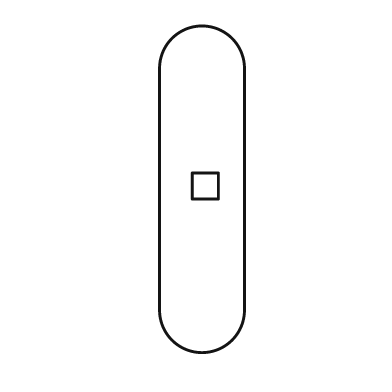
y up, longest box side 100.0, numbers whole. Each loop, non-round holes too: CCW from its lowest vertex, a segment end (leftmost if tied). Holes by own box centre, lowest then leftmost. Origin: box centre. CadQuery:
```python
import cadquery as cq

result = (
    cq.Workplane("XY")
    .moveTo(-13.0, -37.0)
    .threePointArc((0.0, -50.0), (13.0, -37.0))
    .lineTo(13.0, 37.0)
    .threePointArc((0.0, 50.0), (-13.0, 37.0))
    .close()
    .moveTo(-3.0, -3.0)
    .lineTo(5.0, -3.0)
    .lineTo(5.0, 5.0)
    .lineTo(-3.0, 5.0)
    .close()
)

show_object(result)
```